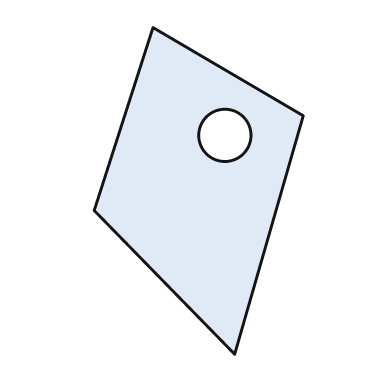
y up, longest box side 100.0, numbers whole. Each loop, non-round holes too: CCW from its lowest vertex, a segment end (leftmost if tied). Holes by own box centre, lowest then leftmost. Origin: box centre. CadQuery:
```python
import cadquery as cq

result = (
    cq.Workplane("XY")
    .moveTo(11.0, -50.0)
    .lineTo(32.0, 23.0)
    .lineTo(-14.0, 50.0)
    .lineTo(-32.0, -6.0)
    .close()
    .moveTo(8.0, 17.0)
    .circle(8.0)
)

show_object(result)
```